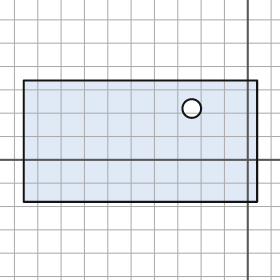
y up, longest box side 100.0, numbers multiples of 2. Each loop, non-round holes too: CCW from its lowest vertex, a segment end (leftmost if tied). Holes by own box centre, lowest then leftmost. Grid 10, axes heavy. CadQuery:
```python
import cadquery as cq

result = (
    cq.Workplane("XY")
    .moveTo(-96.0, -18.0)
    .lineTo(4.0, -18.0)
    .lineTo(4.0, 34.0)
    .lineTo(-96.0, 34.0)
    .close()
    .moveTo(-24.0, 22.0)
    .circle(4.0)
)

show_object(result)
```